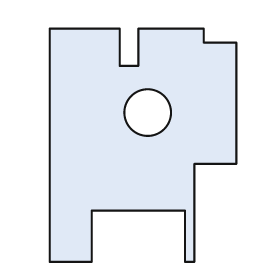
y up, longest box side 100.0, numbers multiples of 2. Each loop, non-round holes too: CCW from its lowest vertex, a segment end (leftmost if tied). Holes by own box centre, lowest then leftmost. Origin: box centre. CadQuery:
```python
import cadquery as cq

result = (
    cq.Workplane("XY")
    .moveTo(-40.0, -50.0)
    .lineTo(-22.0, -50.0)
    .lineTo(-22.0, -28.0)
    .lineTo(18.0, -28.0)
    .lineTo(18.0, -50.0)
    .lineTo(22.0, -50.0)
    .lineTo(22.0, -8.0)
    .lineTo(40.0, -8.0)
    .lineTo(40.0, 44.0)
    .lineTo(26.0, 44.0)
    .lineTo(26.0, 50.0)
    .lineTo(-2.0, 50.0)
    .lineTo(-2.0, 34.0)
    .lineTo(-10.0, 34.0)
    .lineTo(-10.0, 50.0)
    .lineTo(-40.0, 50.0)
    .close()
    .moveTo(2.0, 14.0)
    .circle(10.0)
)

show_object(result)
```